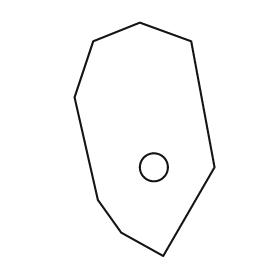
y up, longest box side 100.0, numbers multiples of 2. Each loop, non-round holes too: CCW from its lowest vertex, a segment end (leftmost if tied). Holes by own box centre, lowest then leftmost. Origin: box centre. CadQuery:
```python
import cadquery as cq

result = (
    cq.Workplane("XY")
    .moveTo(8.0, -50.0)
    .lineTo(30.0, -12.0)
    .lineTo(20.0, 42.0)
    .lineTo(-2.0, 50.0)
    .lineTo(-22.0, 42.0)
    .lineTo(-30.0, 18.0)
    .lineTo(-20.0, -26.0)
    .lineTo(-10.0, -40.0)
    .close()
    .moveTo(4.0, -12.0)
    .circle(6.0)
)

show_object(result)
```